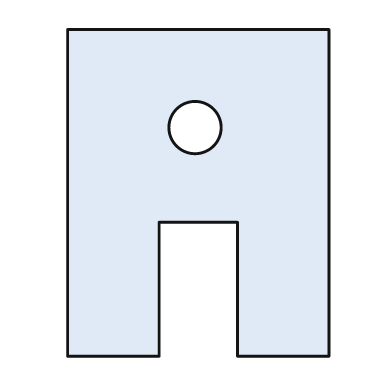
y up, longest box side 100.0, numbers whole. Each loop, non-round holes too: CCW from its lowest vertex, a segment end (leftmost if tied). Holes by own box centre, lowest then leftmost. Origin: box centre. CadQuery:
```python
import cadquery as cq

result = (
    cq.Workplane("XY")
    .moveTo(-40.0, -50.0)
    .lineTo(-12.0, -50.0)
    .lineTo(-12.0, -9.0)
    .lineTo(12.0, -9.0)
    .lineTo(12.0, -50.0)
    .lineTo(40.0, -50.0)
    .lineTo(40.0, 50.0)
    .lineTo(-40.0, 50.0)
    .close()
    .moveTo(-1.0, 20.0)
    .circle(8.0)
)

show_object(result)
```